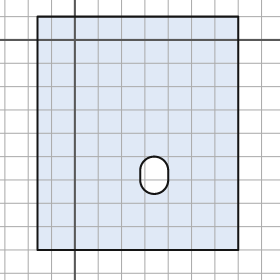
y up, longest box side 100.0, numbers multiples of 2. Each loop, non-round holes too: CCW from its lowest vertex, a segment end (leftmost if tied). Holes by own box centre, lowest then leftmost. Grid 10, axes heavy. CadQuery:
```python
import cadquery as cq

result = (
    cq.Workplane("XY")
    .moveTo(-16.0, -90.0)
    .lineTo(70.0, -90.0)
    .lineTo(70.0, 10.0)
    .lineTo(-16.0, 10.0)
    .close()
    .moveTo(28.0, -60.0)
    .threePointArc((34.0, -66.0), (40.0, -60.0))
    .lineTo(40.0, -56.0)
    .threePointArc((34.0, -50.0), (28.0, -56.0))
    .close()
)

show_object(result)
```